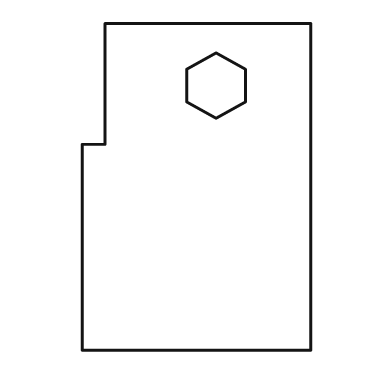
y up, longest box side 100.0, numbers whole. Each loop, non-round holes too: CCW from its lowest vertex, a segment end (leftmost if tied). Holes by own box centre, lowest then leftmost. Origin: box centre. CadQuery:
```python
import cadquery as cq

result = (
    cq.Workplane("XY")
    .moveTo(-35.0, -50.0)
    .lineTo(35.0, -50.0)
    .lineTo(35.0, 50.0)
    .lineTo(-28.0, 50.0)
    .lineTo(-28.0, 13.0)
    .lineTo(-35.0, 13.0)
    .close()
    .moveTo(6.0, 21.0)
    .lineTo(15.0, 26.0)
    .lineTo(15.0, 36.0)
    .lineTo(6.0, 41.0)
    .lineTo(-3.0, 36.0)
    .lineTo(-3.0, 26.0)
    .close()
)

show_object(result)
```